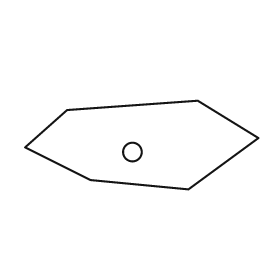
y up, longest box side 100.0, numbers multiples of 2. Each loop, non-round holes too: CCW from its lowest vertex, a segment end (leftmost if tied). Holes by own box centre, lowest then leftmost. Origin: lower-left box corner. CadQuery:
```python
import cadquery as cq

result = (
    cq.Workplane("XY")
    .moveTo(70.0, 0.0)
    .lineTo(100.0, 22.0)
    .lineTo(74.0, 38.0)
    .lineTo(18.0, 34.0)
    .lineTo(0.0, 18.0)
    .lineTo(28.0, 4.0)
    .close()
    .moveTo(46.0, 16.0)
    .circle(4.0)
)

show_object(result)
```